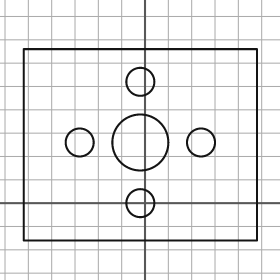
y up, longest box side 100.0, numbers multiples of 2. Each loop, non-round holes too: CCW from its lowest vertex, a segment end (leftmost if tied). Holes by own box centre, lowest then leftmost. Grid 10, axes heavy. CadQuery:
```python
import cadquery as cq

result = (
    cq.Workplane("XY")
    .moveTo(-52.0, -16.0)
    .lineTo(48.0, -16.0)
    .lineTo(48.0, 66.0)
    .lineTo(-52.0, 66.0)
    .close()
    .moveTo(-2.0, 0.0)
    .circle(6.0)
    .moveTo(-28.0, 26.0)
    .circle(6.0)
    .moveTo(-2.0, 26.0)
    .circle(12.0)
    .moveTo(24.0, 26.0)
    .circle(6.0)
    .moveTo(-2.0, 52.0)
    .circle(6.0)
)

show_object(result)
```